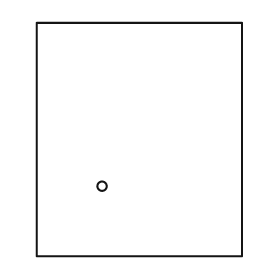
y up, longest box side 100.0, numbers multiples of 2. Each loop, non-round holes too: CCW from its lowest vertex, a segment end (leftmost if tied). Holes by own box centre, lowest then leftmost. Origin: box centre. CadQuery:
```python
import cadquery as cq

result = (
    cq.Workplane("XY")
    .moveTo(-44.0, -50.0)
    .lineTo(44.0, -50.0)
    .lineTo(44.0, 50.0)
    .lineTo(-44.0, 50.0)
    .close()
    .moveTo(-16.0, -20.0)
    .circle(2.0)
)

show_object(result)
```